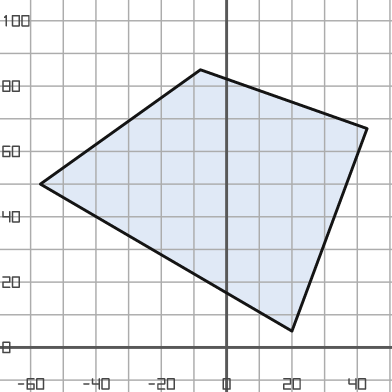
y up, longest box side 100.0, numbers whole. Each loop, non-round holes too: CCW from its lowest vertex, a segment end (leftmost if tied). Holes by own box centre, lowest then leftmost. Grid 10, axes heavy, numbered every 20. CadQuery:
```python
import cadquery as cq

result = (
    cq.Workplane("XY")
    .moveTo(20.0, 5.0)
    .lineTo(43.0, 67.0)
    .lineTo(-8.0, 85.0)
    .lineTo(-57.0, 50.0)
    .close()
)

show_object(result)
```